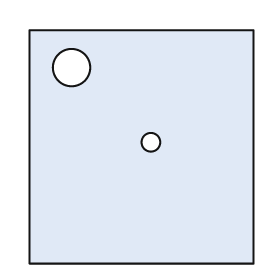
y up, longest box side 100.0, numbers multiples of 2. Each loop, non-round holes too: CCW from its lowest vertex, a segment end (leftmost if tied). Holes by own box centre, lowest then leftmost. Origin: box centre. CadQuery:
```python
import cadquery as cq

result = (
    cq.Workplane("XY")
    .moveTo(-48.0, -50.0)
    .lineTo(48.0, -50.0)
    .lineTo(48.0, 50.0)
    .lineTo(-48.0, 50.0)
    .close()
    .moveTo(4.0, 2.0)
    .circle(4.0)
    .moveTo(-30.0, 34.0)
    .circle(8.0)
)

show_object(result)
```